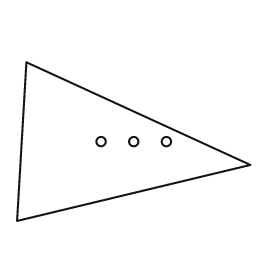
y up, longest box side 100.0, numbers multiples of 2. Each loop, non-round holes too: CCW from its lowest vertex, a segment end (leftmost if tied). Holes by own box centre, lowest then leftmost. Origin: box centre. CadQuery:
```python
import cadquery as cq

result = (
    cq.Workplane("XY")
    .moveTo(-50.0, -34.0)
    .lineTo(50.0, -10.0)
    .lineTo(-46.0, 34.0)
    .close()
    .moveTo(-14.0, 0.0)
    .circle(2.0)
    .moveTo(0.0, 0.0)
    .circle(2.0)
    .moveTo(14.0, 0.0)
    .circle(2.0)
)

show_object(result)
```